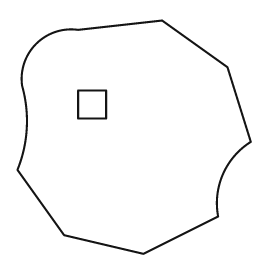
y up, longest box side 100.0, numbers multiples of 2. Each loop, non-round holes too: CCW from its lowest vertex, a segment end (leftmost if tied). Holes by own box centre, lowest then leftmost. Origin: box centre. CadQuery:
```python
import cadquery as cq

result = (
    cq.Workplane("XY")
    .moveTo(4.0, -50.0)
    .lineTo(36.0, -34.0)
    .threePointArc((38.0, -16.0), (50.0, -2.0))
    .lineTo(40.0, 30.0)
    .lineTo(12.0, 50.0)
    .lineTo(-24.0, 46.0)
    .threePointArc((-42.0, 40.0), (-48.0, 22.0))
    .threePointArc((-46.0, 4.0), (-50.0, -14.0))
    .lineTo(-30.0, -42.0)
    .close()
    .moveTo(-24.0, 8.0)
    .lineTo(-12.0, 8.0)
    .lineTo(-12.0, 20.0)
    .lineTo(-24.0, 20.0)
    .close()
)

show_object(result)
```